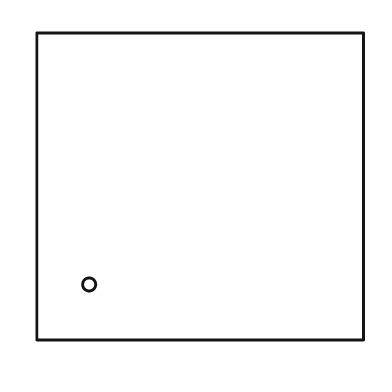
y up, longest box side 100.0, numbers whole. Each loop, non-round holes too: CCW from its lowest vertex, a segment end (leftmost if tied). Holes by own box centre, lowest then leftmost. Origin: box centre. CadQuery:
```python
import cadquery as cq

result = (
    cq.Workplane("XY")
    .moveTo(-50.0, -47.0)
    .lineTo(50.0, -47.0)
    .lineTo(50.0, 47.0)
    .lineTo(-50.0, 47.0)
    .close()
    .moveTo(-34.0, -30.0)
    .circle(2.0)
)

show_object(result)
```